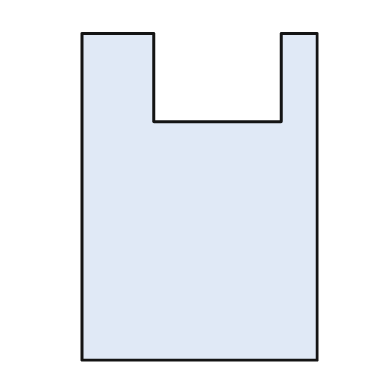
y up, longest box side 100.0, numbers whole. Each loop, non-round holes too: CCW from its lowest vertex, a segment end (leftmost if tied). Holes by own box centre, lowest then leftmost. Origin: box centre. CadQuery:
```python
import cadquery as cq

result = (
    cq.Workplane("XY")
    .moveTo(-36.0, -50.0)
    .lineTo(36.0, -50.0)
    .lineTo(36.0, 50.0)
    .lineTo(25.0, 50.0)
    .lineTo(25.0, 23.0)
    .lineTo(-14.0, 23.0)
    .lineTo(-14.0, 50.0)
    .lineTo(-36.0, 50.0)
    .close()
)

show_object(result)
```